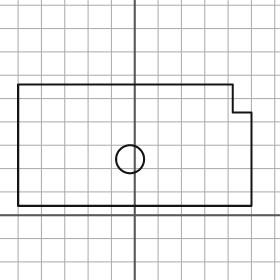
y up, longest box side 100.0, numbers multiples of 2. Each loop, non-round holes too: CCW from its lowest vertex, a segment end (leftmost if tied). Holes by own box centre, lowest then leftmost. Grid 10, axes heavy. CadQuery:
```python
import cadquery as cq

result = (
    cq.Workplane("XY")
    .moveTo(-50.0, 4.0)
    .lineTo(50.0, 4.0)
    .lineTo(50.0, 44.0)
    .lineTo(42.0, 44.0)
    .lineTo(42.0, 56.0)
    .lineTo(-50.0, 56.0)
    .close()
    .moveTo(-2.0, 24.0)
    .circle(6.0)
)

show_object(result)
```